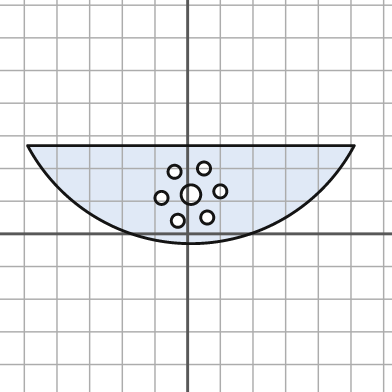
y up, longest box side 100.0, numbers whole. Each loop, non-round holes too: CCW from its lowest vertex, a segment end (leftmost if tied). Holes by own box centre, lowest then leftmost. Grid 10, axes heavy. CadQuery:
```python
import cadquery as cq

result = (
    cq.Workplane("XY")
    .moveTo(-49.0, 27.0)
    .threePointArc((1.0, -3.0), (51.0, 27.0))
    .close()
    .moveTo(-3.0, 4.0)
    .circle(2.0)
    .moveTo(6.0, 5.0)
    .circle(2.0)
    .moveTo(-8.0, 11.0)
    .circle(2.0)
    .moveTo(1.0, 12.0)
    .circle(3.0)
    .moveTo(10.0, 13.0)
    .circle(2.0)
    .moveTo(-4.0, 19.0)
    .circle(2.0)
    .moveTo(5.0, 20.0)
    .circle(2.0)
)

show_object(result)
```